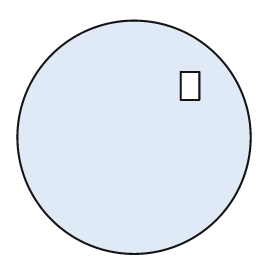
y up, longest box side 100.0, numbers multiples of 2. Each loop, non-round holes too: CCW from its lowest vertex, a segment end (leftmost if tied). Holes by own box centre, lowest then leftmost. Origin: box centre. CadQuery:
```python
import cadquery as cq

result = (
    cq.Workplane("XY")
    .moveTo(0.0, 0.0)
    .circle(50.0)
    .moveTo(20.0, 16.0)
    .lineTo(28.0, 16.0)
    .lineTo(28.0, 28.0)
    .lineTo(20.0, 28.0)
    .close()
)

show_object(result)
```